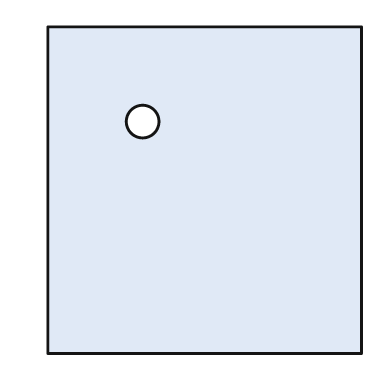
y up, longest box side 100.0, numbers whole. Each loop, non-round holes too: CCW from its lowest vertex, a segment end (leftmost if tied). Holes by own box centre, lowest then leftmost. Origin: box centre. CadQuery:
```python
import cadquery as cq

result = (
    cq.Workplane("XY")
    .moveTo(-48.0, -50.0)
    .lineTo(48.0, -50.0)
    .lineTo(48.0, 50.0)
    .lineTo(-48.0, 50.0)
    .close()
    .moveTo(-19.0, 21.0)
    .circle(5.0)
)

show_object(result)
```